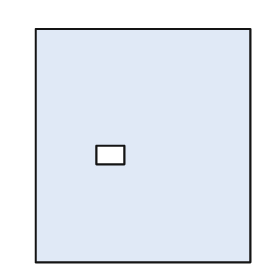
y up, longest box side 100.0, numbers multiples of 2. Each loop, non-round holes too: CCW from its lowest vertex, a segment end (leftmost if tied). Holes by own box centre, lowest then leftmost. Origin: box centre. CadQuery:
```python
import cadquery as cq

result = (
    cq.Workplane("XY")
    .moveTo(-46.0, -50.0)
    .lineTo(46.0, -50.0)
    .lineTo(46.0, 50.0)
    .lineTo(-46.0, 50.0)
    .close()
    .moveTo(-20.0, -8.0)
    .lineTo(-8.0, -8.0)
    .lineTo(-8.0, 0.0)
    .lineTo(-20.0, 0.0)
    .close()
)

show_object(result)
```